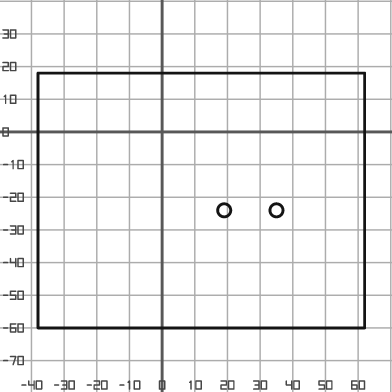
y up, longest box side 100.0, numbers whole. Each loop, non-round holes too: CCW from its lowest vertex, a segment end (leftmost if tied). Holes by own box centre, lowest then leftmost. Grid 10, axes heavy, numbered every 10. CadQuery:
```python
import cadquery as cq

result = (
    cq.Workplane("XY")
    .moveTo(-38.0, -60.0)
    .lineTo(62.0, -60.0)
    .lineTo(62.0, 18.0)
    .lineTo(-38.0, 18.0)
    .close()
    .moveTo(19.0, -24.0)
    .circle(2.0)
    .moveTo(35.0, -24.0)
    .circle(2.0)
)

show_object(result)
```